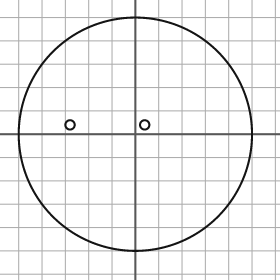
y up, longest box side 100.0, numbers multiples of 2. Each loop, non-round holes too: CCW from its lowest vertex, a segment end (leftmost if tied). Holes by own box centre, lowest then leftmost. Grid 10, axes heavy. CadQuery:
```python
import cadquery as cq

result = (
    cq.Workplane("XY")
    .moveTo(0.0, 0.0)
    .circle(50.0)
    .moveTo(-28.0, 4.0)
    .circle(2.0)
    .moveTo(4.0, 4.0)
    .circle(2.0)
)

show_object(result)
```